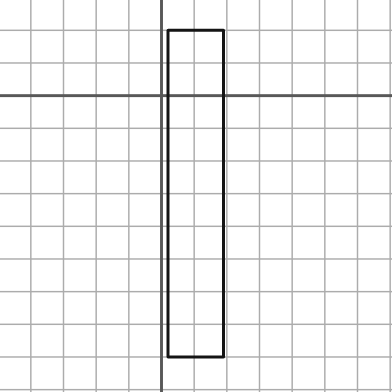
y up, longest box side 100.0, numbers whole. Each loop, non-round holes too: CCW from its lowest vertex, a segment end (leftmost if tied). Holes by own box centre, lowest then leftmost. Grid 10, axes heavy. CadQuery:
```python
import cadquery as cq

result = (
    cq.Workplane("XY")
    .moveTo(2.0, -80.0)
    .lineTo(19.0, -80.0)
    .lineTo(19.0, 20.0)
    .lineTo(2.0, 20.0)
    .close()
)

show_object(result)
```